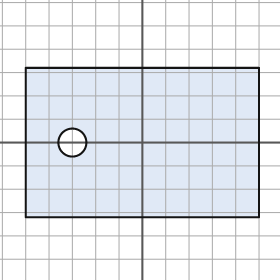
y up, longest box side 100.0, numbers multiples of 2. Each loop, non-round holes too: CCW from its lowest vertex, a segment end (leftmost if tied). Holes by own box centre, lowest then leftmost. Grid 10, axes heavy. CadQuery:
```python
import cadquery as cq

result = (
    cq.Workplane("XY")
    .moveTo(-50.0, -32.0)
    .lineTo(50.0, -32.0)
    .lineTo(50.0, 32.0)
    .lineTo(-50.0, 32.0)
    .close()
    .moveTo(-30.0, 0.0)
    .circle(6.0)
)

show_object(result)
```